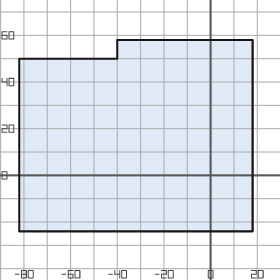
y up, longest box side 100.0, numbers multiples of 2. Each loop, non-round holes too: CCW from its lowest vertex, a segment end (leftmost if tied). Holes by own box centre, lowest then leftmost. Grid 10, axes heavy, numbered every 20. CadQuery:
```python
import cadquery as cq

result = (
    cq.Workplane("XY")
    .moveTo(-82.0, -24.0)
    .lineTo(18.0, -24.0)
    .lineTo(18.0, 58.0)
    .lineTo(-40.0, 58.0)
    .lineTo(-40.0, 50.0)
    .lineTo(-82.0, 50.0)
    .close()
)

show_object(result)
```